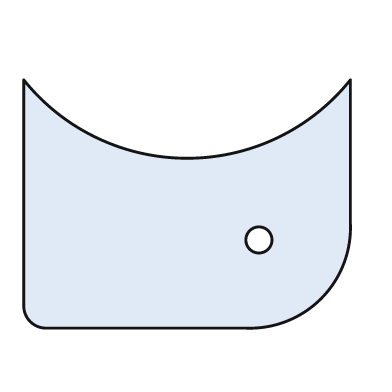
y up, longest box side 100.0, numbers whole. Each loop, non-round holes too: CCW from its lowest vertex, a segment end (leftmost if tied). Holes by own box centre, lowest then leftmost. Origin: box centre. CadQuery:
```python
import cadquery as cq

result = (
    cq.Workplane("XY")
    .moveTo(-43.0, -38.0)
    .lineTo(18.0, -38.0)
    .threePointArc((41.0, -29.0), (50.0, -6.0))
    .lineTo(50.0, 38.0)
    .threePointArc((0.0, 14.0), (-50.0, 38.0))
    .lineTo(-50.0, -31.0)
    .threePointArc((-48.0, -36.0), (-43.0, -38.0))
    .close()
    .moveTo(22.0, -11.0)
    .circle(4.0)
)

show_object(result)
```